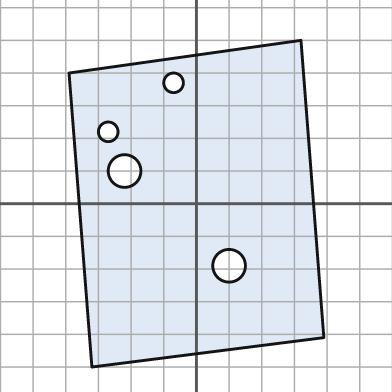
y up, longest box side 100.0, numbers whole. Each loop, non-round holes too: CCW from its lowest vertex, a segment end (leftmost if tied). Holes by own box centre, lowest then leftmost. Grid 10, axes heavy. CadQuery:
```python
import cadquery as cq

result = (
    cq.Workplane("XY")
    .moveTo(-32.0, -50.0)
    .lineTo(39.0, -41.0)
    .lineTo(32.0, 50.0)
    .lineTo(-39.0, 40.0)
    .close()
    .moveTo(10.0, -19.0)
    .circle(5.0)
    .moveTo(-22.0, 10.0)
    .circle(5.0)
    .moveTo(-27.0, 22.0)
    .circle(3.0)
    .moveTo(-7.0, 37.0)
    .circle(3.0)
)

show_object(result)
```